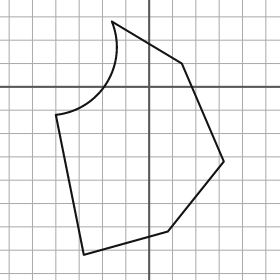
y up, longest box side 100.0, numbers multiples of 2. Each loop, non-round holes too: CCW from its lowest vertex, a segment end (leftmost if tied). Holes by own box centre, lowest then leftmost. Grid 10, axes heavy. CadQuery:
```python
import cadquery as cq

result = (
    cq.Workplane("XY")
    .moveTo(-28.0, -72.0)
    .lineTo(8.0, -62.0)
    .lineTo(32.0, -32.0)
    .lineTo(14.0, 10.0)
    .lineTo(-16.0, 28.0)
    .threePointArc((-18.0, 2.0), (-40.0, -12.0))
    .close()
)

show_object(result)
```